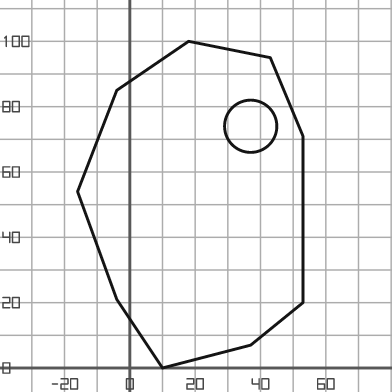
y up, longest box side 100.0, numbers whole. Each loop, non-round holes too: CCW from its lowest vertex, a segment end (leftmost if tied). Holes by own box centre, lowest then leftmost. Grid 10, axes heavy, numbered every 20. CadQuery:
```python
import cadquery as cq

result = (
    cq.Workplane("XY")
    .moveTo(10.0, 0.0)
    .lineTo(37.0, 7.0)
    .lineTo(53.0, 20.0)
    .lineTo(53.0, 71.0)
    .lineTo(43.0, 95.0)
    .lineTo(18.0, 100.0)
    .lineTo(-4.0, 85.0)
    .lineTo(-16.0, 54.0)
    .lineTo(-4.0, 21.0)
    .close()
    .moveTo(37.0, 74.0)
    .circle(8.0)
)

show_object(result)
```